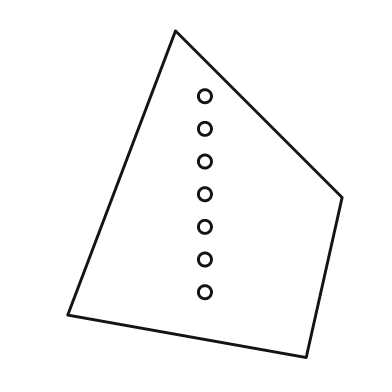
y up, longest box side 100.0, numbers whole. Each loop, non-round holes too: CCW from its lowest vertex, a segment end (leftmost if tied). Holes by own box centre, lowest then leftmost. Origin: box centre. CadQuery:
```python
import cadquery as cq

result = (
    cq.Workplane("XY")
    .moveTo(31.0, -50.0)
    .lineTo(42.0, -1.0)
    .lineTo(-9.0, 50.0)
    .lineTo(-42.0, -37.0)
    .close()
    .moveTo(0.0, -30.0)
    .circle(2.0)
    .moveTo(0.0, -20.0)
    .circle(2.0)
    .moveTo(0.0, -10.0)
    .circle(2.0)
    .moveTo(0.0, 0.0)
    .circle(2.0)
    .moveTo(0.0, 10.0)
    .circle(2.0)
    .moveTo(0.0, 20.0)
    .circle(2.0)
    .moveTo(0.0, 30.0)
    .circle(2.0)
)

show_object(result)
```